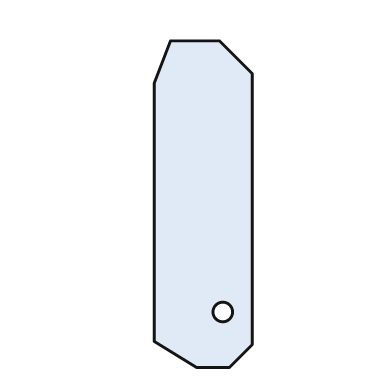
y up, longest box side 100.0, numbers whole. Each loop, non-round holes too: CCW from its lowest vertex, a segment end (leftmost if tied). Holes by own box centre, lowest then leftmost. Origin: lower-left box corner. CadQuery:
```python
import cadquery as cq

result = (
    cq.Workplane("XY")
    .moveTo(13.0, 0.0)
    .lineTo(23.0, 0.0)
    .lineTo(30.0, 7.0)
    .lineTo(30.0, 90.0)
    .lineTo(20.0, 100.0)
    .lineTo(5.0, 100.0)
    .lineTo(0.0, 87.0)
    .lineTo(0.0, 8.0)
    .close()
    .moveTo(21.0, 17.0)
    .circle(3.0)
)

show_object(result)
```